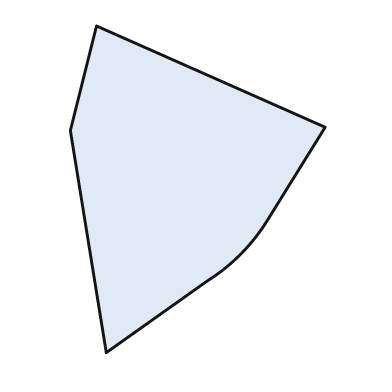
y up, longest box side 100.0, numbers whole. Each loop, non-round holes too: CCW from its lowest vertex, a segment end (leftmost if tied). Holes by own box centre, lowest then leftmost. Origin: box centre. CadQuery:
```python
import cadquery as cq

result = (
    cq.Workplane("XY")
    .moveTo(-28.0, -50.0)
    .lineTo(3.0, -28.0)
    .threePointArc((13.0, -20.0), (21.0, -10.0))
    .lineTo(39.0, 19.0)
    .lineTo(-31.0, 50.0)
    .lineTo(-39.0, 18.0)
    .close()
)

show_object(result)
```